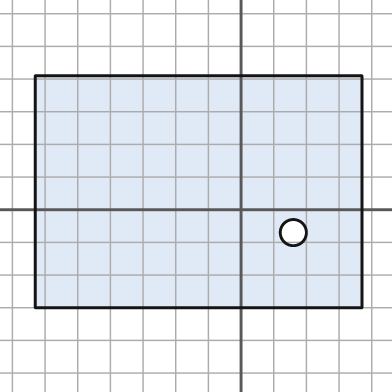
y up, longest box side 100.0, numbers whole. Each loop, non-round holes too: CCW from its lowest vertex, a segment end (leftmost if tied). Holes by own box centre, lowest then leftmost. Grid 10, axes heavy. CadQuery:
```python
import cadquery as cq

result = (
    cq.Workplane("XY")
    .moveTo(-63.0, -30.0)
    .lineTo(37.0, -30.0)
    .lineTo(37.0, 41.0)
    .lineTo(-63.0, 41.0)
    .close()
    .moveTo(16.0, -7.0)
    .circle(4.0)
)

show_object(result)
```